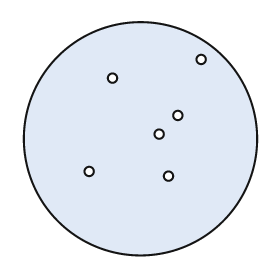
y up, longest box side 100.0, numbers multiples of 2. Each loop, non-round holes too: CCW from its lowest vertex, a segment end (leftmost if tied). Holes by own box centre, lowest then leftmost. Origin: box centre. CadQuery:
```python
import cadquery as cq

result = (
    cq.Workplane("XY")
    .moveTo(0.0, 0.0)
    .circle(50.0)
    .moveTo(12.0, -16.0)
    .circle(2.0)
    .moveTo(-22.0, -14.0)
    .circle(2.0)
    .moveTo(8.0, 2.0)
    .circle(2.0)
    .moveTo(16.0, 10.0)
    .circle(2.0)
    .moveTo(-12.0, 26.0)
    .circle(2.0)
    .moveTo(26.0, 34.0)
    .circle(2.0)
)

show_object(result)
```